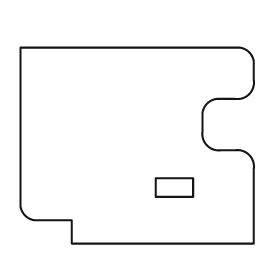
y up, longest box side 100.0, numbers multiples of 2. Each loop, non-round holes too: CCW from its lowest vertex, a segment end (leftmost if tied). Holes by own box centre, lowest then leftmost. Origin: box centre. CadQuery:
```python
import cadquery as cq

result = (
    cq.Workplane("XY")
    .moveTo(-28.0, -42.0)
    .lineTo(50.0, -42.0)
    .lineTo(50.0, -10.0)
    .threePointArc((48.0, -4.0), (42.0, -2.0))
    .lineTo(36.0, -2.0)
    .threePointArc((30.0, 0.0), (28.0, 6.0))
    .lineTo(28.0, 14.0)
    .threePointArc((30.0, 18.0), (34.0, 20.0))
    .lineTo(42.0, 20.0)
    .threePointArc((48.0, 22.0), (50.0, 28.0))
    .lineTo(50.0, 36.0)
    .threePointArc((48.0, 40.0), (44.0, 42.0))
    .lineTo(-50.0, 42.0)
    .lineTo(-50.0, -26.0)
    .threePointArc((-48.0, -30.0), (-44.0, -32.0))
    .lineTo(-28.0, -32.0)
    .close()
    .moveTo(8.0, -22.0)
    .lineTo(24.0, -22.0)
    .lineTo(24.0, -14.0)
    .lineTo(8.0, -14.0)
    .close()
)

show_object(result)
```